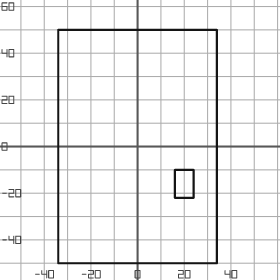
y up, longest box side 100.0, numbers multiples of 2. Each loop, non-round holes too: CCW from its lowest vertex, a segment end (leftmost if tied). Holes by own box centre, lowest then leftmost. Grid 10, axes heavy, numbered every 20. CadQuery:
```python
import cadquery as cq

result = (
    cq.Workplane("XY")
    .moveTo(-34.0, -50.0)
    .lineTo(34.0, -50.0)
    .lineTo(34.0, 50.0)
    .lineTo(-34.0, 50.0)
    .close()
    .moveTo(16.0, -22.0)
    .lineTo(24.0, -22.0)
    .lineTo(24.0, -10.0)
    .lineTo(16.0, -10.0)
    .close()
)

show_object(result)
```